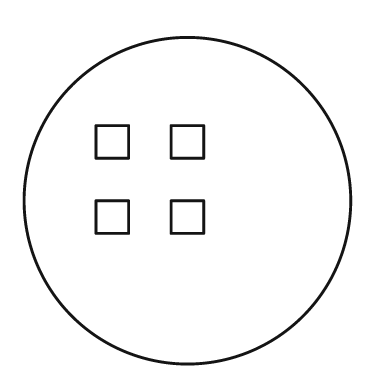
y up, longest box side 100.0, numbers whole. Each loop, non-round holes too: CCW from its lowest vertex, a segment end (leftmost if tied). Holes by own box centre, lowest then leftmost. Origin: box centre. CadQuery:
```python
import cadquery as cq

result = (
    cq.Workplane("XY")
    .moveTo(0.0, 0.0)
    .circle(50.0)
    .moveTo(-28.0, -10.0)
    .lineTo(-18.0, -10.0)
    .lineTo(-18.0, 0.0)
    .lineTo(-28.0, 0.0)
    .close()
    .moveTo(-5.0, -10.0)
    .lineTo(5.0, -10.0)
    .lineTo(5.0, 0.0)
    .lineTo(-5.0, 0.0)
    .close()
    .moveTo(-28.0, 13.0)
    .lineTo(-18.0, 13.0)
    .lineTo(-18.0, 23.0)
    .lineTo(-28.0, 23.0)
    .close()
    .moveTo(-5.0, 13.0)
    .lineTo(5.0, 13.0)
    .lineTo(5.0, 23.0)
    .lineTo(-5.0, 23.0)
    .close()
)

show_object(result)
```